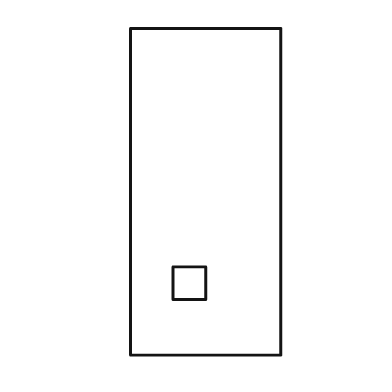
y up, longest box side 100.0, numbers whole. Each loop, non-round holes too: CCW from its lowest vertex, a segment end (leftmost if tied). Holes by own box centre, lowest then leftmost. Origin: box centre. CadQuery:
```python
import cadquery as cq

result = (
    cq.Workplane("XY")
    .moveTo(-23.0, -50.0)
    .lineTo(23.0, -50.0)
    .lineTo(23.0, 50.0)
    .lineTo(-23.0, 50.0)
    .close()
    .moveTo(-10.0, -33.0)
    .lineTo(0.0, -33.0)
    .lineTo(0.0, -23.0)
    .lineTo(-10.0, -23.0)
    .close()
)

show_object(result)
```